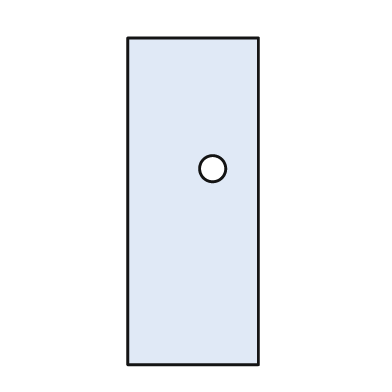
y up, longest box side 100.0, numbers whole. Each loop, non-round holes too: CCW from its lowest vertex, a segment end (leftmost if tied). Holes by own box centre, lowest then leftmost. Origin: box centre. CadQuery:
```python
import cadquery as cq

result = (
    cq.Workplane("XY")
    .moveTo(-20.0, -50.0)
    .lineTo(20.0, -50.0)
    .lineTo(20.0, 50.0)
    .lineTo(-20.0, 50.0)
    .close()
    .moveTo(6.0, 10.0)
    .circle(4.0)
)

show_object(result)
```